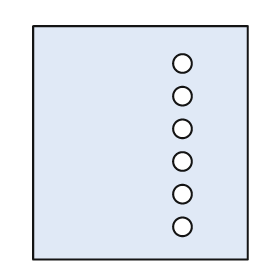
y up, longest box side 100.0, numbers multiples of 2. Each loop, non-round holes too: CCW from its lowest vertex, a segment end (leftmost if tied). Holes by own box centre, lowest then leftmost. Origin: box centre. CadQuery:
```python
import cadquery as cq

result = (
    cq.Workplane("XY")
    .moveTo(-46.0, -50.0)
    .lineTo(46.0, -50.0)
    .lineTo(46.0, 50.0)
    .lineTo(-46.0, 50.0)
    .close()
    .moveTo(18.0, -36.0)
    .circle(4.0)
    .moveTo(18.0, -22.0)
    .circle(4.0)
    .moveTo(18.0, -8.0)
    .circle(4.0)
    .moveTo(18.0, 6.0)
    .circle(4.0)
    .moveTo(18.0, 20.0)
    .circle(4.0)
    .moveTo(18.0, 34.0)
    .circle(4.0)
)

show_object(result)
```